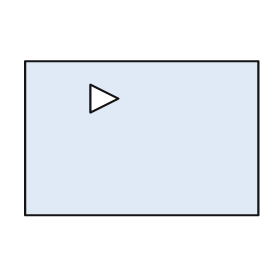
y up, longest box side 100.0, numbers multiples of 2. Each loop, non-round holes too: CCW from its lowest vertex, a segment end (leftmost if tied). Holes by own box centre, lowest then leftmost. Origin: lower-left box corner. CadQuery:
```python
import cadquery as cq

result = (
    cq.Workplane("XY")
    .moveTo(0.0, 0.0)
    .lineTo(100.0, 0.0)
    .lineTo(100.0, 66.0)
    .lineTo(0.0, 66.0)
    .close()
    .moveTo(28.0, 44.0)
    .lineTo(40.0, 50.0)
    .lineTo(28.0, 56.0)
    .close()
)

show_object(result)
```